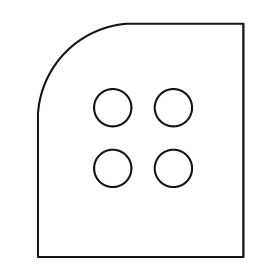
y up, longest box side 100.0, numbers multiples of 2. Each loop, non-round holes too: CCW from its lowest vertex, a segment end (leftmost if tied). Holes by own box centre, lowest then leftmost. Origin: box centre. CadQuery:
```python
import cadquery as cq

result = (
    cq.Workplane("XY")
    .moveTo(-44.0, -50.0)
    .lineTo(44.0, -50.0)
    .lineTo(44.0, 50.0)
    .lineTo(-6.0, 50.0)
    .threePointArc((-32.0, 38.0), (-44.0, 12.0))
    .close()
    .moveTo(-12.0, -12.0)
    .circle(8.0)
    .moveTo(14.0, -12.0)
    .circle(8.0)
    .moveTo(-12.0, 14.0)
    .circle(8.0)
    .moveTo(14.0, 14.0)
    .circle(8.0)
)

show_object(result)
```